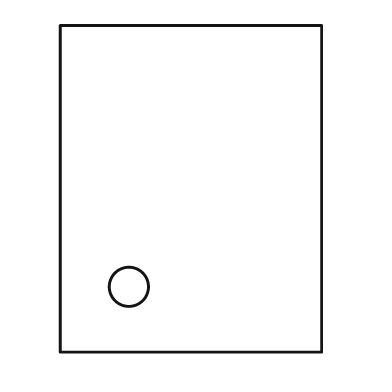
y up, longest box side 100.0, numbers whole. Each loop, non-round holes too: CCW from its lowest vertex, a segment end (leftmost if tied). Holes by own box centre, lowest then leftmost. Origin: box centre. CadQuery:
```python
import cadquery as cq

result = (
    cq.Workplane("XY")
    .moveTo(-40.0, -50.0)
    .lineTo(40.0, -50.0)
    .lineTo(40.0, 50.0)
    .lineTo(-40.0, 50.0)
    .close()
    .moveTo(-19.0, -30.0)
    .circle(6.0)
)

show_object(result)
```